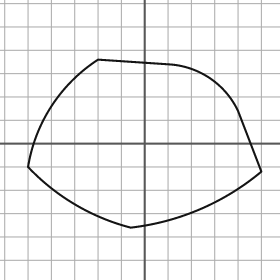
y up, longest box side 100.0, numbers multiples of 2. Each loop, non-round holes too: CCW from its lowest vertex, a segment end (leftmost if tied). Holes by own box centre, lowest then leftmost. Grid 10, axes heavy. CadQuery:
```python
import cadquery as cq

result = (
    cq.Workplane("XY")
    .moveTo(-6.0, -36.0)
    .threePointArc((24.0, -28.0), (50.0, -12.0))
    .lineTo(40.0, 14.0)
    .threePointArc((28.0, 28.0), (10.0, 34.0))
    .lineTo(-20.0, 36.0)
    .threePointArc((-40.0, 16.0), (-50.0, -10.0))
    .threePointArc((-30.0, -26.0), (-6.0, -36.0))
    .close()
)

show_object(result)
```